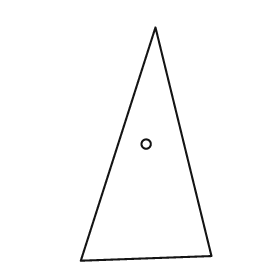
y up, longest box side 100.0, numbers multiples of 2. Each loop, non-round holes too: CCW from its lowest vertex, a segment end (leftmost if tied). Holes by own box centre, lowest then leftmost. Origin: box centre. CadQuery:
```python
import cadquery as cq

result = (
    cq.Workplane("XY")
    .moveTo(-28.0, -50.0)
    .lineTo(28.0, -48.0)
    .lineTo(4.0, 50.0)
    .close()
    .moveTo(0.0, 0.0)
    .circle(2.0)
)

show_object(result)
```